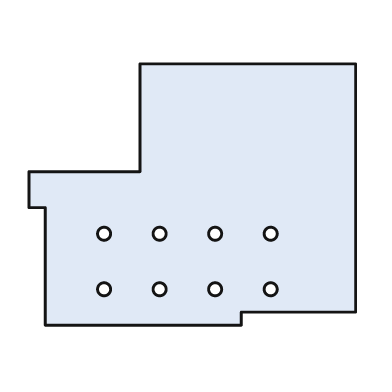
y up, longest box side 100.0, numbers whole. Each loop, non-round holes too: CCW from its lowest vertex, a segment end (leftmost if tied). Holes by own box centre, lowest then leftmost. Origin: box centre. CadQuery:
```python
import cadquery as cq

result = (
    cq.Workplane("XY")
    .moveTo(-45.0, -40.0)
    .lineTo(15.0, -40.0)
    .lineTo(15.0, -36.0)
    .lineTo(50.0, -36.0)
    .lineTo(50.0, 40.0)
    .lineTo(-16.0, 40.0)
    .lineTo(-16.0, 7.0)
    .lineTo(-50.0, 7.0)
    .lineTo(-50.0, -4.0)
    .lineTo(-45.0, -4.0)
    .close()
    .moveTo(-27.0, -29.0)
    .circle(2.0)
    .moveTo(-10.0, -29.0)
    .circle(2.0)
    .moveTo(7.0, -29.0)
    .circle(2.0)
    .moveTo(24.0, -29.0)
    .circle(2.0)
    .moveTo(-27.0, -12.0)
    .circle(2.0)
    .moveTo(-10.0, -12.0)
    .circle(2.0)
    .moveTo(7.0, -12.0)
    .circle(2.0)
    .moveTo(24.0, -12.0)
    .circle(2.0)
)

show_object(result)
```